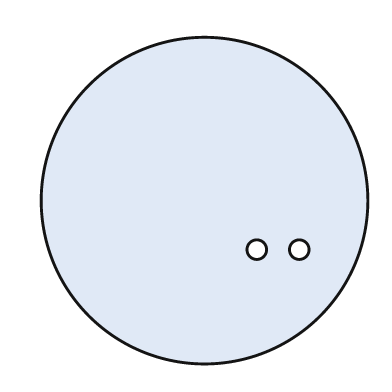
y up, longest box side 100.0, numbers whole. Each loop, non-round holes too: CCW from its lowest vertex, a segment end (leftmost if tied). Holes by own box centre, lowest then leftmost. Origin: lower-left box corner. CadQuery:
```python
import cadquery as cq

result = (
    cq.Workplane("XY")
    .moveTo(50.0, 50.0)
    .circle(50.0)
    .moveTo(66.0, 35.0)
    .circle(3.0)
    .moveTo(79.0, 35.0)
    .circle(3.0)
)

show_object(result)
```